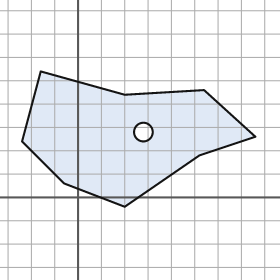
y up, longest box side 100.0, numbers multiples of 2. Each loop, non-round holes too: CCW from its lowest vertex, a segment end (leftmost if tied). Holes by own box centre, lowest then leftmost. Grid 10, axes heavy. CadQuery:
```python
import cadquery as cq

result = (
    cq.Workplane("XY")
    .moveTo(20.0, -4.0)
    .lineTo(52.0, 18.0)
    .lineTo(76.0, 26.0)
    .lineTo(54.0, 46.0)
    .lineTo(20.0, 44.0)
    .lineTo(-16.0, 54.0)
    .lineTo(-24.0, 24.0)
    .lineTo(-6.0, 6.0)
    .close()
    .moveTo(28.0, 28.0)
    .circle(4.0)
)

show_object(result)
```